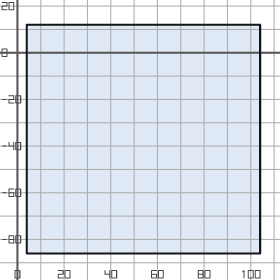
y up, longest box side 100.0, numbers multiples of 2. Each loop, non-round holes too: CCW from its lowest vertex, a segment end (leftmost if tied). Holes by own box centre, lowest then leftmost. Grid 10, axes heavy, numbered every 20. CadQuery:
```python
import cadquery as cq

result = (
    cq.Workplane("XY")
    .moveTo(4.0, -86.0)
    .lineTo(104.0, -86.0)
    .lineTo(104.0, 12.0)
    .lineTo(4.0, 12.0)
    .close()
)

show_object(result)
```